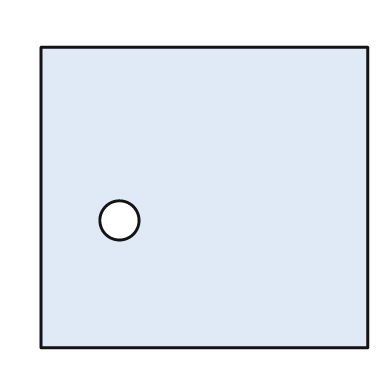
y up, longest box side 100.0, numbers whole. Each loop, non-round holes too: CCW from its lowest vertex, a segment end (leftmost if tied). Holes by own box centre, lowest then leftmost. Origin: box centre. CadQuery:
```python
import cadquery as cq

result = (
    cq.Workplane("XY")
    .moveTo(-50.0, -46.0)
    .lineTo(50.0, -46.0)
    .lineTo(50.0, 46.0)
    .lineTo(-50.0, 46.0)
    .close()
    .moveTo(-26.0, -7.0)
    .circle(6.0)
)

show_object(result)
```